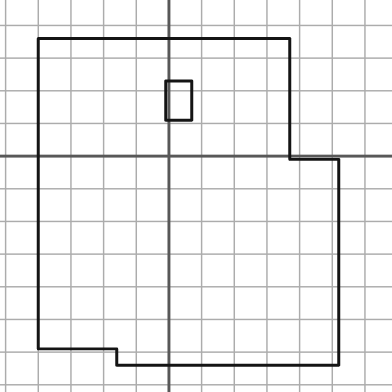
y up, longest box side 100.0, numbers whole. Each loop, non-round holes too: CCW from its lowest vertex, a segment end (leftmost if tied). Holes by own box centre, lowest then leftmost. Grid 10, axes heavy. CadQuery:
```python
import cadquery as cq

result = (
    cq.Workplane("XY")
    .moveTo(-16.0, -64.0)
    .lineTo(52.0, -64.0)
    .lineTo(52.0, -1.0)
    .lineTo(37.0, -1.0)
    .lineTo(37.0, 36.0)
    .lineTo(-40.0, 36.0)
    .lineTo(-40.0, -59.0)
    .lineTo(-16.0, -59.0)
    .close()
    .moveTo(-1.0, 11.0)
    .lineTo(7.0, 11.0)
    .lineTo(7.0, 23.0)
    .lineTo(-1.0, 23.0)
    .close()
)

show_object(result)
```